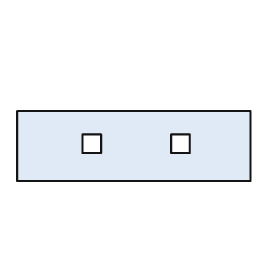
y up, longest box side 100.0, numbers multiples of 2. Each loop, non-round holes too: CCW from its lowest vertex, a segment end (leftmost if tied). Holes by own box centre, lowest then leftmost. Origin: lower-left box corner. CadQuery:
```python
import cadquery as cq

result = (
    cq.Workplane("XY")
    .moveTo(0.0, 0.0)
    .lineTo(100.0, 0.0)
    .lineTo(100.0, 30.0)
    .lineTo(0.0, 30.0)
    .close()
    .moveTo(28.0, 12.0)
    .lineTo(36.0, 12.0)
    .lineTo(36.0, 20.0)
    .lineTo(28.0, 20.0)
    .close()
    .moveTo(66.0, 12.0)
    .lineTo(74.0, 12.0)
    .lineTo(74.0, 20.0)
    .lineTo(66.0, 20.0)
    .close()
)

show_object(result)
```